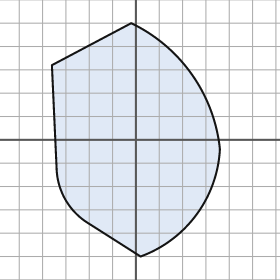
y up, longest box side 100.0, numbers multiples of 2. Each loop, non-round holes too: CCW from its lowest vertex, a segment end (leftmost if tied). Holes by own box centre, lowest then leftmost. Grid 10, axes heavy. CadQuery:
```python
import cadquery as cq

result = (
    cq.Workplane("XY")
    .moveTo(2.0, -50.0)
    .threePointArc((26.0, -32.0), (36.0, -4.0))
    .threePointArc((24.0, 28.0), (-2.0, 50.0))
    .lineTo(-36.0, 32.0)
    .lineTo(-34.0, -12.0)
    .threePointArc((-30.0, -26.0), (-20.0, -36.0))
    .close()
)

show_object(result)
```